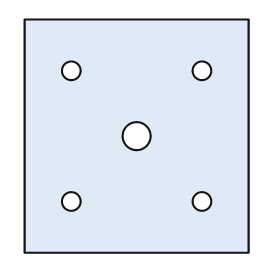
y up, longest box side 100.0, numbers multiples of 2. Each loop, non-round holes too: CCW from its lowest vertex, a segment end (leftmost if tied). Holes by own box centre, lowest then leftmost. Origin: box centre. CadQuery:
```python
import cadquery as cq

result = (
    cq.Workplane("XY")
    .moveTo(-48.0, -50.0)
    .lineTo(48.0, -50.0)
    .lineTo(48.0, 50.0)
    .lineTo(-48.0, 50.0)
    .close()
    .moveTo(-28.0, -28.0)
    .circle(4.0)
    .moveTo(28.0, -28.0)
    .circle(4.0)
    .moveTo(0.0, 0.0)
    .circle(6.0)
    .moveTo(-28.0, 28.0)
    .circle(4.0)
    .moveTo(28.0, 28.0)
    .circle(4.0)
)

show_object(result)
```